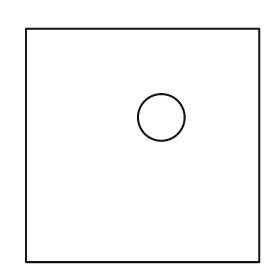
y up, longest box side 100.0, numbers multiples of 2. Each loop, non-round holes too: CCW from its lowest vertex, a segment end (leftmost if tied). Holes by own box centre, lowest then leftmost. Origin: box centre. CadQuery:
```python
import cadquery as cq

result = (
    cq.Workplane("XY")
    .moveTo(-50.0, -50.0)
    .lineTo(50.0, -50.0)
    .lineTo(50.0, 50.0)
    .lineTo(-50.0, 50.0)
    .close()
    .moveTo(8.0, 12.0)
    .circle(10.0)
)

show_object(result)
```